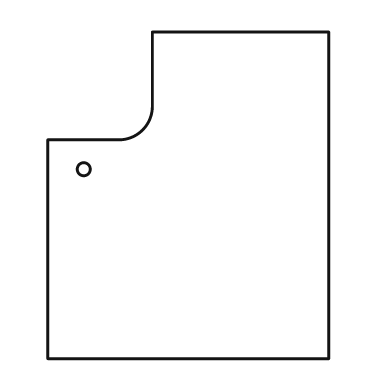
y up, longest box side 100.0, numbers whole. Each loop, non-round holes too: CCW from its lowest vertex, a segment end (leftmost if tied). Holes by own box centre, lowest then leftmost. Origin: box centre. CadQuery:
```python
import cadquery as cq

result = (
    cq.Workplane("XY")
    .moveTo(-43.0, -50.0)
    .lineTo(43.0, -50.0)
    .lineTo(43.0, 50.0)
    .lineTo(-11.0, 50.0)
    .lineTo(-11.0, 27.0)
    .threePointArc((-14.0, 20.0), (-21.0, 17.0))
    .lineTo(-43.0, 17.0)
    .close()
    .moveTo(-32.0, 8.0)
    .circle(2.0)
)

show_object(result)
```